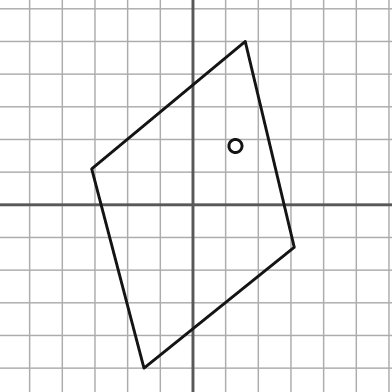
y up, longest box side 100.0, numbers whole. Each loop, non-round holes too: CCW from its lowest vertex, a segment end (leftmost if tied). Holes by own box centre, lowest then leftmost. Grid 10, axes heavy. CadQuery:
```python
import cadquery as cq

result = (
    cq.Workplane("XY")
    .moveTo(-15.0, -50.0)
    .lineTo(31.0, -13.0)
    .lineTo(16.0, 50.0)
    .lineTo(-31.0, 11.0)
    .close()
    .moveTo(13.0, 18.0)
    .circle(2.0)
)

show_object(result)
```